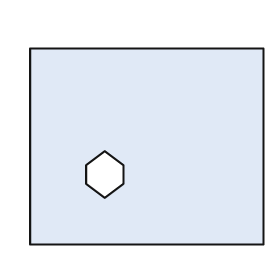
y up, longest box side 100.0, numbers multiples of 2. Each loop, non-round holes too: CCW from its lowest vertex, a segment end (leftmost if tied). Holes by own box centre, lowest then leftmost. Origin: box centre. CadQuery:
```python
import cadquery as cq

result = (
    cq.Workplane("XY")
    .moveTo(-50.0, -42.0)
    .lineTo(50.0, -42.0)
    .lineTo(50.0, 42.0)
    .lineTo(-50.0, 42.0)
    .close()
    .moveTo(-18.0, -22.0)
    .lineTo(-10.0, -16.0)
    .lineTo(-10.0, -8.0)
    .lineTo(-18.0, -2.0)
    .lineTo(-26.0, -8.0)
    .lineTo(-26.0, -16.0)
    .close()
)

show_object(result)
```